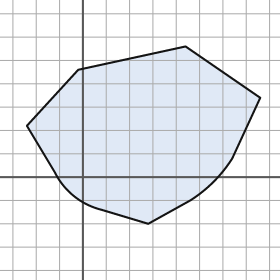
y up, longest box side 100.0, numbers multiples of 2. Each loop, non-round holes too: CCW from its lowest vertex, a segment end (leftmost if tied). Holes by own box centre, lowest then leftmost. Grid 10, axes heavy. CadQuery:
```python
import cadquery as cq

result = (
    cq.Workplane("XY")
    .moveTo(28.0, -20.0)
    .lineTo(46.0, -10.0)
    .threePointArc((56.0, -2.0), (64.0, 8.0))
    .lineTo(76.0, 34.0)
    .lineTo(44.0, 56.0)
    .lineTo(-2.0, 46.0)
    .lineTo(-24.0, 22.0)
    .lineTo(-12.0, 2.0)
    .threePointArc((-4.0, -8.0), (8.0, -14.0))
    .close()
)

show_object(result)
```